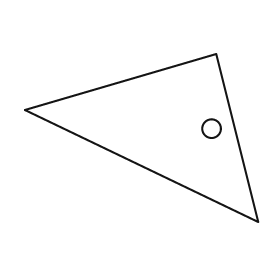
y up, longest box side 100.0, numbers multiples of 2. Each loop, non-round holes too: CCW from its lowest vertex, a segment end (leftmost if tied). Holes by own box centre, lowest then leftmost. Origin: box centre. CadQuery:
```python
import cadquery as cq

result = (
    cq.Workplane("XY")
    .moveTo(50.0, -36.0)
    .lineTo(32.0, 36.0)
    .lineTo(-50.0, 12.0)
    .close()
    .moveTo(30.0, 4.0)
    .circle(4.0)
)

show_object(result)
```